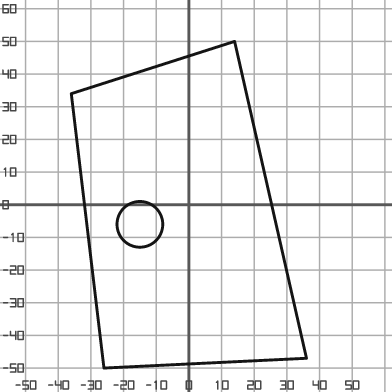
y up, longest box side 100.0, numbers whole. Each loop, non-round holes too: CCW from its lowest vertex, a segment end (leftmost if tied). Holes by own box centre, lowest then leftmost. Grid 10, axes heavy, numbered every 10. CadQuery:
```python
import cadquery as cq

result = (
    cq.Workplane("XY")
    .moveTo(-26.0, -50.0)
    .lineTo(36.0, -47.0)
    .lineTo(14.0, 50.0)
    .lineTo(-36.0, 34.0)
    .close()
    .moveTo(-15.0, -6.0)
    .circle(7.0)
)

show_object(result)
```